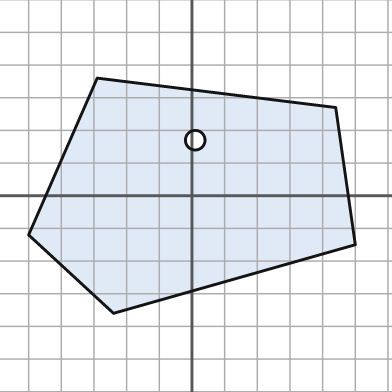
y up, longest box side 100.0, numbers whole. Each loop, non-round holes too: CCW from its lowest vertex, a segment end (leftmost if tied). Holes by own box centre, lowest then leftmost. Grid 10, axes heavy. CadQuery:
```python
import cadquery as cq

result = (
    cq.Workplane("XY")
    .moveTo(-24.0, -36.0)
    .lineTo(50.0, -15.0)
    .lineTo(44.0, 27.0)
    .lineTo(-29.0, 36.0)
    .lineTo(-50.0, -12.0)
    .close()
    .moveTo(1.0, 17.0)
    .circle(3.0)
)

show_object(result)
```